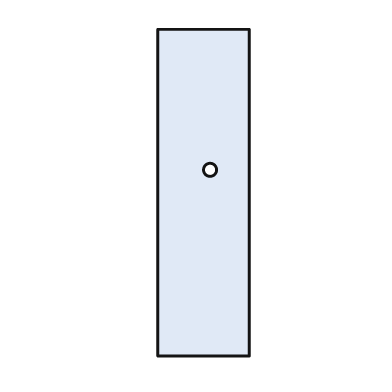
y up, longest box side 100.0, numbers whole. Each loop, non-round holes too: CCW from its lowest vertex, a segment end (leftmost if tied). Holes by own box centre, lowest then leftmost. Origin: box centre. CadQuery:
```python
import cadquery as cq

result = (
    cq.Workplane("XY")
    .moveTo(-14.0, -50.0)
    .lineTo(14.0, -50.0)
    .lineTo(14.0, 50.0)
    .lineTo(-14.0, 50.0)
    .close()
    .moveTo(2.0, 7.0)
    .circle(2.0)
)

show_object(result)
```